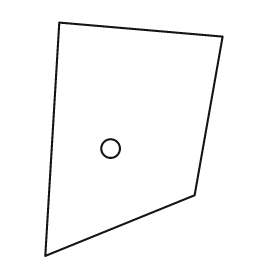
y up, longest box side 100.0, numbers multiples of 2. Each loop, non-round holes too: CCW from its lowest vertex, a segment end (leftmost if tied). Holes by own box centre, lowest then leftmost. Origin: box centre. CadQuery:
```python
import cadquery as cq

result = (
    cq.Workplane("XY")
    .moveTo(-38.0, -50.0)
    .lineTo(26.0, -24.0)
    .lineTo(38.0, 44.0)
    .lineTo(-32.0, 50.0)
    .close()
    .moveTo(-10.0, -4.0)
    .circle(4.0)
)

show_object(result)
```